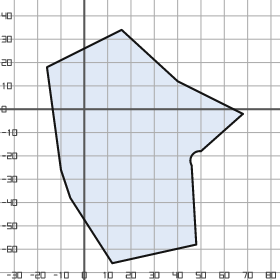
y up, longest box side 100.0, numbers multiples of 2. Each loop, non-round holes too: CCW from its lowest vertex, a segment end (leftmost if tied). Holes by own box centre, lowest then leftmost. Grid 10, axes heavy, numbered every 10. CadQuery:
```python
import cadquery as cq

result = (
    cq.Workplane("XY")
    .moveTo(12.0, -66.0)
    .lineTo(48.0, -58.0)
    .lineTo(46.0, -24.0)
    .threePointArc((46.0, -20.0), (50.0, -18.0))
    .lineTo(68.0, -2.0)
    .lineTo(40.0, 12.0)
    .lineTo(16.0, 34.0)
    .lineTo(-16.0, 18.0)
    .lineTo(-10.0, -26.0)
    .lineTo(-6.0, -38.0)
    .close()
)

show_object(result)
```